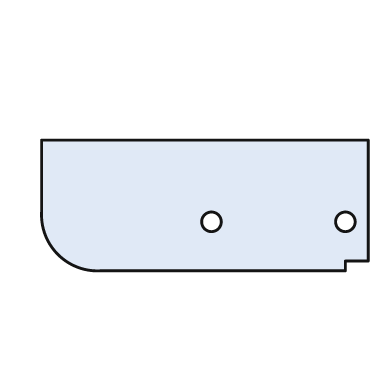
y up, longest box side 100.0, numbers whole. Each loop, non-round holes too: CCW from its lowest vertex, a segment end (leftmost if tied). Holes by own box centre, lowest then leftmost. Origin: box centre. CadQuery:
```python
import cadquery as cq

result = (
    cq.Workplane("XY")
    .moveTo(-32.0, -20.0)
    .lineTo(43.0, -20.0)
    .lineTo(43.0, -17.0)
    .lineTo(50.0, -17.0)
    .lineTo(50.0, 20.0)
    .lineTo(-50.0, 20.0)
    .lineTo(-50.0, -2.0)
    .threePointArc((-45.0, -15.0), (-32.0, -20.0))
    .close()
    .moveTo(2.0, -5.0)
    .circle(3.0)
    .moveTo(43.0, -5.0)
    .circle(3.0)
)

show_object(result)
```